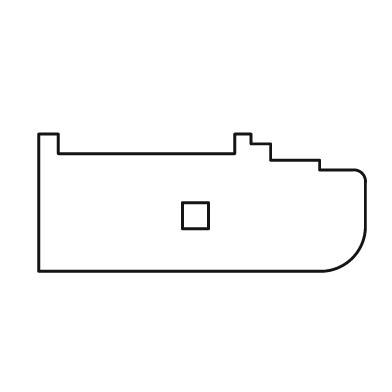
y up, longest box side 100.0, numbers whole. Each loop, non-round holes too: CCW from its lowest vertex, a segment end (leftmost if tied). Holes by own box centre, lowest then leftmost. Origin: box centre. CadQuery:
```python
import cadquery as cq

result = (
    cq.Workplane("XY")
    .moveTo(-50.0, -21.0)
    .lineTo(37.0, -21.0)
    .threePointArc((46.0, -17.0), (50.0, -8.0))
    .lineTo(50.0, 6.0)
    .threePointArc((49.0, 9.0), (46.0, 10.0))
    .lineTo(36.0, 10.0)
    .lineTo(36.0, 13.0)
    .lineTo(21.0, 13.0)
    .lineTo(21.0, 18.0)
    .lineTo(15.0, 18.0)
    .lineTo(15.0, 21.0)
    .lineTo(10.0, 21.0)
    .lineTo(10.0, 15.0)
    .lineTo(-44.0, 15.0)
    .lineTo(-44.0, 21.0)
    .lineTo(-50.0, 21.0)
    .close()
    .moveTo(-6.0, -8.0)
    .lineTo(2.0, -8.0)
    .lineTo(2.0, 0.0)
    .lineTo(-6.0, 0.0)
    .close()
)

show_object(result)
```